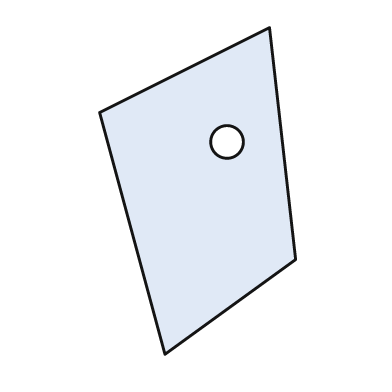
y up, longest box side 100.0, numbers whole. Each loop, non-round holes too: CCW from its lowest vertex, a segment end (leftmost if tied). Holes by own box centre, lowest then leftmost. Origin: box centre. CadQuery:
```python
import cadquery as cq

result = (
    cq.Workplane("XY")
    .moveTo(-10.0, -50.0)
    .lineTo(30.0, -21.0)
    .lineTo(22.0, 50.0)
    .lineTo(-30.0, 24.0)
    .close()
    .moveTo(9.0, 15.0)
    .circle(5.0)
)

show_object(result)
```